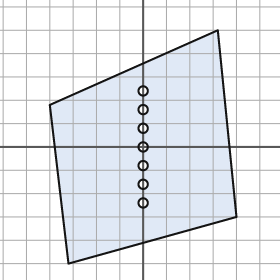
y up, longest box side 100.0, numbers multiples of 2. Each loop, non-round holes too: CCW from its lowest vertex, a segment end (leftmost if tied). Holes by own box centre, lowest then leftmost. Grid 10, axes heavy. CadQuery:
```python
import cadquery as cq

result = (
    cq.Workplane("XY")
    .moveTo(-32.0, -50.0)
    .lineTo(40.0, -30.0)
    .lineTo(32.0, 50.0)
    .lineTo(-40.0, 18.0)
    .close()
    .moveTo(0.0, -24.0)
    .circle(2.0)
    .moveTo(0.0, -16.0)
    .circle(2.0)
    .moveTo(0.0, -8.0)
    .circle(2.0)
    .moveTo(0.0, 0.0)
    .circle(2.0)
    .moveTo(0.0, 8.0)
    .circle(2.0)
    .moveTo(0.0, 16.0)
    .circle(2.0)
    .moveTo(0.0, 24.0)
    .circle(2.0)
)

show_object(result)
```